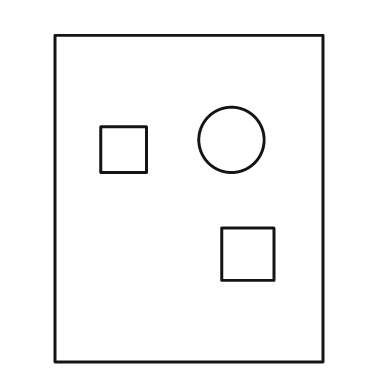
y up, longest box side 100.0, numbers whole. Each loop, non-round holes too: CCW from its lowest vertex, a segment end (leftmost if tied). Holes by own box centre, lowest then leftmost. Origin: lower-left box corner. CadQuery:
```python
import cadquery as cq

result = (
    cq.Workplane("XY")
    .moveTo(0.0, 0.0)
    .lineTo(82.0, 0.0)
    .lineTo(82.0, 100.0)
    .lineTo(0.0, 100.0)
    .close()
    .moveTo(51.0, 25.0)
    .lineTo(67.0, 25.0)
    .lineTo(67.0, 41.0)
    .lineTo(51.0, 41.0)
    .close()
    .moveTo(14.0, 58.0)
    .lineTo(28.0, 58.0)
    .lineTo(28.0, 72.0)
    .lineTo(14.0, 72.0)
    .close()
    .moveTo(54.0, 68.0)
    .circle(10.0)
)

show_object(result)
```